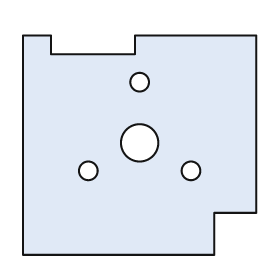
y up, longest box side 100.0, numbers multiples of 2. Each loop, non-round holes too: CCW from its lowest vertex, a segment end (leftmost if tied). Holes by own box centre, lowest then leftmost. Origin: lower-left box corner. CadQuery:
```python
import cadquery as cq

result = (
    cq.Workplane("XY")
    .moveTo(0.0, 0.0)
    .lineTo(82.0, 0.0)
    .lineTo(82.0, 18.0)
    .lineTo(100.0, 18.0)
    .lineTo(100.0, 94.0)
    .lineTo(48.0, 94.0)
    .lineTo(48.0, 86.0)
    .lineTo(12.0, 86.0)
    .lineTo(12.0, 94.0)
    .lineTo(0.0, 94.0)
    .close()
    .moveTo(28.0, 36.0)
    .circle(4.0)
    .moveTo(72.0, 36.0)
    .circle(4.0)
    .moveTo(50.0, 48.0)
    .circle(8.0)
    .moveTo(50.0, 74.0)
    .circle(4.0)
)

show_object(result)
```